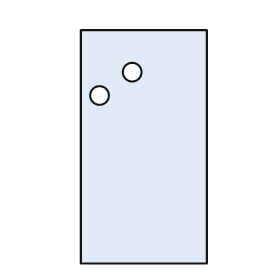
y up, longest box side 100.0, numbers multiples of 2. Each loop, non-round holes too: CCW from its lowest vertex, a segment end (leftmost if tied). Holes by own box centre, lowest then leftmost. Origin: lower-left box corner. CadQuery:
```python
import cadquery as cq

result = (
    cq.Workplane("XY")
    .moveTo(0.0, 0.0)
    .lineTo(54.0, 0.0)
    .lineTo(54.0, 100.0)
    .lineTo(0.0, 100.0)
    .close()
    .moveTo(8.0, 72.0)
    .circle(4.0)
    .moveTo(22.0, 82.0)
    .circle(4.0)
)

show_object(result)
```